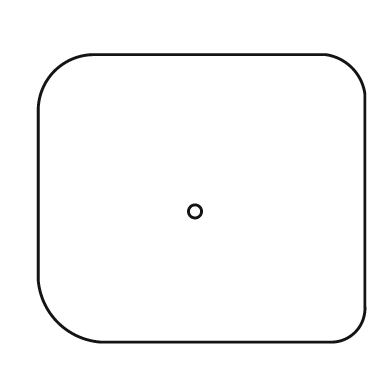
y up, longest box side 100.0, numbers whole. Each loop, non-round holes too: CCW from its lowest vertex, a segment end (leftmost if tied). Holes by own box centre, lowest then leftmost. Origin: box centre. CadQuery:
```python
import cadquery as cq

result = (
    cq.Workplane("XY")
    .moveTo(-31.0, -44.0)
    .lineTo(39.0, -44.0)
    .threePointArc((47.0, -41.0), (50.0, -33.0))
    .lineTo(50.0, 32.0)
    .threePointArc((46.0, 40.0), (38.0, 44.0))
    .lineTo(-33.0, 44.0)
    .threePointArc((-45.0, 39.0), (-50.0, 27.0))
    .lineTo(-50.0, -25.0)
    .threePointArc((-44.0, -38.0), (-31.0, -44.0))
    .close()
    .moveTo(-2.0, -4.0)
    .circle(2.0)
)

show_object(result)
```